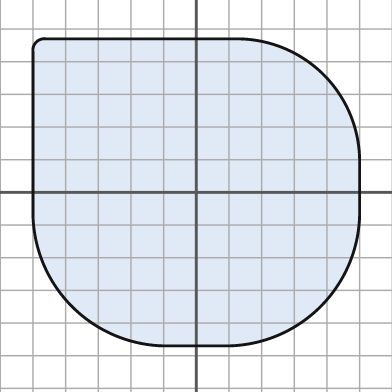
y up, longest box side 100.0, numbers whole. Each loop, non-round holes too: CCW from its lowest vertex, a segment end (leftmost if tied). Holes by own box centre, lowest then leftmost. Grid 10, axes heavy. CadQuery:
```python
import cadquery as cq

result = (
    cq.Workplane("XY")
    .moveTo(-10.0, -47.0)
    .lineTo(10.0, -47.0)
    .threePointArc((38.0, -35.0), (50.0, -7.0))
    .lineTo(50.0, 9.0)
    .threePointArc((39.0, 36.0), (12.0, 47.0))
    .lineTo(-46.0, 47.0)
    .threePointArc((-49.0, 46.0), (-50.0, 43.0))
    .lineTo(-50.0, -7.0)
    .threePointArc((-38.0, -35.0), (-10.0, -47.0))
    .close()
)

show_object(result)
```